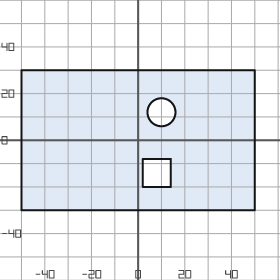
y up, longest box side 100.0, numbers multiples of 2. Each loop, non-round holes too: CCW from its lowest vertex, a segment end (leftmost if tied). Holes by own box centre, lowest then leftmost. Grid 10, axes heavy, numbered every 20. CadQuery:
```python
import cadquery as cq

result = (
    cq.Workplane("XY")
    .moveTo(-50.0, -30.0)
    .lineTo(50.0, -30.0)
    .lineTo(50.0, 30.0)
    .lineTo(-50.0, 30.0)
    .close()
    .moveTo(2.0, -20.0)
    .lineTo(14.0, -20.0)
    .lineTo(14.0, -8.0)
    .lineTo(2.0, -8.0)
    .close()
    .moveTo(10.0, 12.0)
    .circle(6.0)
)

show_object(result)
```